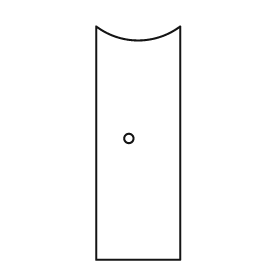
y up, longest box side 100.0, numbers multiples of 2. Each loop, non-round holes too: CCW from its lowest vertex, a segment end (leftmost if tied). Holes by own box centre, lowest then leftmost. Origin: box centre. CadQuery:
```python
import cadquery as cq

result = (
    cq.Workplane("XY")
    .moveTo(-18.0, -50.0)
    .lineTo(18.0, -50.0)
    .lineTo(18.0, 50.0)
    .threePointArc((0.0, 44.0), (-18.0, 50.0))
    .close()
    .moveTo(-4.0, 2.0)
    .circle(2.0)
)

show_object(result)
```